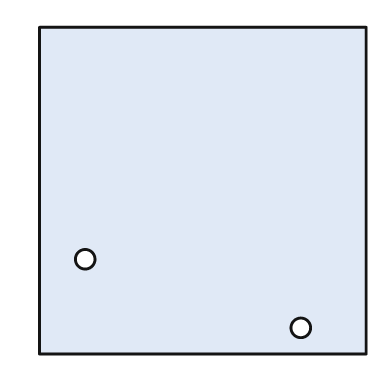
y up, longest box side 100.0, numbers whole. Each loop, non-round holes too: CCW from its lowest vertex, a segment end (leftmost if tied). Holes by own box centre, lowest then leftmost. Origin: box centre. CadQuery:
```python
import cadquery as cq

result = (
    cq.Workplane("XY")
    .moveTo(-50.0, -50.0)
    .lineTo(50.0, -50.0)
    .lineTo(50.0, 50.0)
    .lineTo(-50.0, 50.0)
    .close()
    .moveTo(30.0, -42.0)
    .circle(3.0)
    .moveTo(-36.0, -21.0)
    .circle(3.0)
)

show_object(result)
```